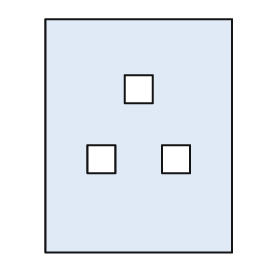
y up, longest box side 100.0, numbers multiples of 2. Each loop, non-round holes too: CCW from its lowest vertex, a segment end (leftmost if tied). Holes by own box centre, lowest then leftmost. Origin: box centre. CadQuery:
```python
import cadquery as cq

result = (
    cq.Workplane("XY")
    .moveTo(-40.0, -50.0)
    .lineTo(40.0, -50.0)
    .lineTo(40.0, 50.0)
    .lineTo(-40.0, 50.0)
    .close()
    .moveTo(-22.0, -16.0)
    .lineTo(-10.0, -16.0)
    .lineTo(-10.0, -4.0)
    .lineTo(-22.0, -4.0)
    .close()
    .moveTo(10.0, -16.0)
    .lineTo(22.0, -16.0)
    .lineTo(22.0, -4.0)
    .lineTo(10.0, -4.0)
    .close()
    .moveTo(-6.0, 14.0)
    .lineTo(6.0, 14.0)
    .lineTo(6.0, 26.0)
    .lineTo(-6.0, 26.0)
    .close()
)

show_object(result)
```